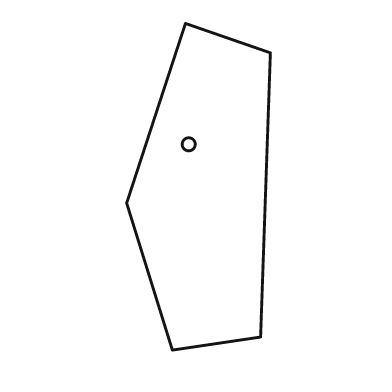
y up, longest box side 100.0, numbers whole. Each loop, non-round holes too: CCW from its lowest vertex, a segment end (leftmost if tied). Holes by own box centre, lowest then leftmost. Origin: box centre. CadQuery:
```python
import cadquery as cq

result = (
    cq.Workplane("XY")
    .moveTo(-8.0, -50.0)
    .lineTo(19.0, -46.0)
    .lineTo(22.0, 41.0)
    .lineTo(-4.0, 50.0)
    .lineTo(-22.0, -5.0)
    .close()
    .moveTo(-3.0, 13.0)
    .circle(2.0)
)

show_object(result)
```